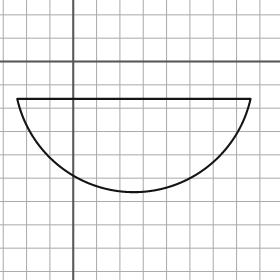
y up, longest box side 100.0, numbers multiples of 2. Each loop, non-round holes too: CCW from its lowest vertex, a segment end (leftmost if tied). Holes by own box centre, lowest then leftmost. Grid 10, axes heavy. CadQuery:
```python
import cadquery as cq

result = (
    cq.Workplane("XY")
    .moveTo(-24.0, -16.0)
    .threePointArc((26.0, -56.0), (76.0, -16.0))
    .close()
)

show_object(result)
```